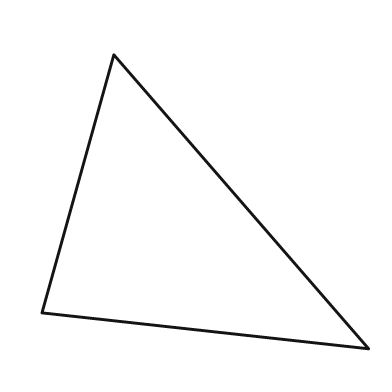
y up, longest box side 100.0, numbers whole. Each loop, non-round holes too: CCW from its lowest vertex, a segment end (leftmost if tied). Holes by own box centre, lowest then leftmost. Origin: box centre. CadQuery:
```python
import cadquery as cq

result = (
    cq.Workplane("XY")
    .moveTo(50.0, -45.0)
    .lineTo(-28.0, 45.0)
    .lineTo(-50.0, -34.0)
    .close()
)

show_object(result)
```